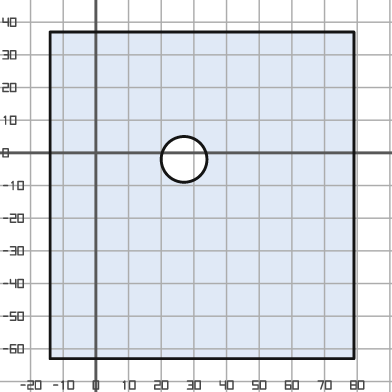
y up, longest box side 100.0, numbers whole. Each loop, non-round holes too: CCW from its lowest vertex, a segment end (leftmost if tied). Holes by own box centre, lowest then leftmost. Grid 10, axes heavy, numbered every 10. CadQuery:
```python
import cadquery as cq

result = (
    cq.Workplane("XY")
    .moveTo(-14.0, -63.0)
    .lineTo(79.0, -63.0)
    .lineTo(79.0, 37.0)
    .lineTo(-14.0, 37.0)
    .close()
    .moveTo(27.0, -2.0)
    .circle(7.0)
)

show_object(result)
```